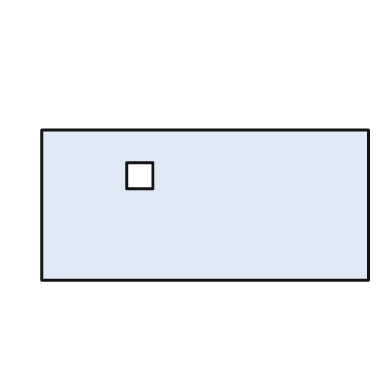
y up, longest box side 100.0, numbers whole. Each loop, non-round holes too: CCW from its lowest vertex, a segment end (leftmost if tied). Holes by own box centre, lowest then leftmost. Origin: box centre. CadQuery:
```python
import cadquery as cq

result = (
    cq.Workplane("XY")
    .moveTo(-50.0, -23.0)
    .lineTo(50.0, -23.0)
    .lineTo(50.0, 23.0)
    .lineTo(-50.0, 23.0)
    .close()
    .moveTo(-24.0, 5.0)
    .lineTo(-16.0, 5.0)
    .lineTo(-16.0, 13.0)
    .lineTo(-24.0, 13.0)
    .close()
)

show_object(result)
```